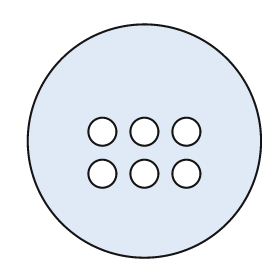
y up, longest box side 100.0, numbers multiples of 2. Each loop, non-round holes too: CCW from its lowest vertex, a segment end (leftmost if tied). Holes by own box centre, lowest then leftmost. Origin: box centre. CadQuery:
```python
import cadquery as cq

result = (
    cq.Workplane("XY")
    .moveTo(0.0, 0.0)
    .circle(50.0)
    .moveTo(-18.0, -14.0)
    .circle(6.0)
    .moveTo(0.0, -14.0)
    .circle(6.0)
    .moveTo(18.0, -14.0)
    .circle(6.0)
    .moveTo(-18.0, 4.0)
    .circle(6.0)
    .moveTo(0.0, 4.0)
    .circle(6.0)
    .moveTo(18.0, 4.0)
    .circle(6.0)
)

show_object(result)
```